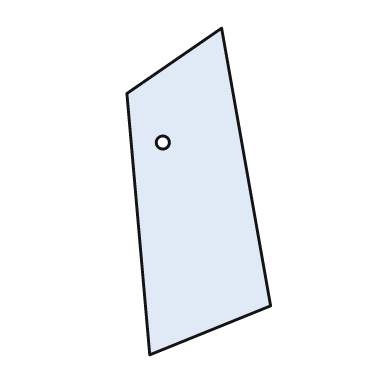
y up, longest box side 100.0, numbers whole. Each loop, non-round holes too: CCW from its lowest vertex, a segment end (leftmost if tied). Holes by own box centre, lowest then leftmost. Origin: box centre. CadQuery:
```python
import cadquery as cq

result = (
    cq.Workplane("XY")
    .moveTo(-15.0, -50.0)
    .lineTo(22.0, -35.0)
    .lineTo(7.0, 50.0)
    .lineTo(-22.0, 30.0)
    .close()
    .moveTo(-11.0, 15.0)
    .circle(2.0)
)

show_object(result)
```